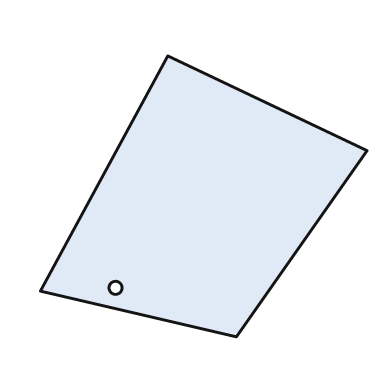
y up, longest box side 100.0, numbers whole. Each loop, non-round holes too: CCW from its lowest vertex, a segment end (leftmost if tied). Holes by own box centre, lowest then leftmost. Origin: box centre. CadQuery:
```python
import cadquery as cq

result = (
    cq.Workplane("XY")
    .moveTo(10.0, -43.0)
    .lineTo(50.0, 14.0)
    .lineTo(-11.0, 43.0)
    .lineTo(-50.0, -29.0)
    .close()
    .moveTo(-27.0, -28.0)
    .circle(2.0)
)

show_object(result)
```